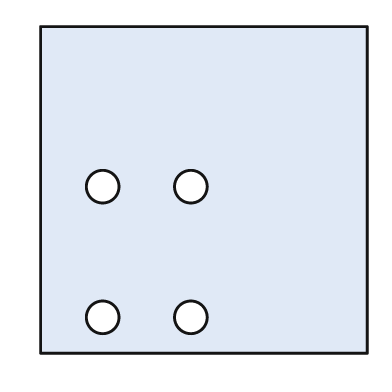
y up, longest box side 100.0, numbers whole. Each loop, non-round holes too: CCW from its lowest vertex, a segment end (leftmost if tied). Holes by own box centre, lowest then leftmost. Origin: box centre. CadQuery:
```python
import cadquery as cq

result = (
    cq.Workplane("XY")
    .moveTo(-50.0, -50.0)
    .lineTo(50.0, -50.0)
    .lineTo(50.0, 50.0)
    .lineTo(-50.0, 50.0)
    .close()
    .moveTo(-31.0, -39.0)
    .circle(5.0)
    .moveTo(-4.0, -39.0)
    .circle(5.0)
    .moveTo(-31.0, 1.0)
    .circle(5.0)
    .moveTo(-4.0, 1.0)
    .circle(5.0)
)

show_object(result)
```